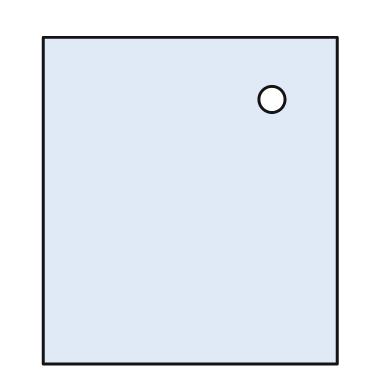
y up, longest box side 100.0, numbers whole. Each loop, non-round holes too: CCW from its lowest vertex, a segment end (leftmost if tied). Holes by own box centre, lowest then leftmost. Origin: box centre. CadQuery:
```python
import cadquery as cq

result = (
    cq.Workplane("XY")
    .moveTo(-45.0, -50.0)
    .lineTo(45.0, -50.0)
    .lineTo(45.0, 50.0)
    .lineTo(-45.0, 50.0)
    .close()
    .moveTo(25.0, 31.0)
    .circle(4.0)
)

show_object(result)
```